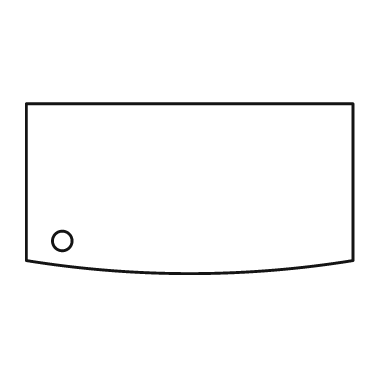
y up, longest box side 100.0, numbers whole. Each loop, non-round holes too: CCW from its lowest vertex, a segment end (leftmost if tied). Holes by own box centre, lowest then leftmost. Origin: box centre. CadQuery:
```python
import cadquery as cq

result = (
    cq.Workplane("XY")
    .moveTo(-50.0, -22.0)
    .threePointArc((0.0, -26.0), (50.0, -22.0))
    .lineTo(50.0, 26.0)
    .lineTo(-50.0, 26.0)
    .close()
    .moveTo(-39.0, -16.0)
    .circle(3.0)
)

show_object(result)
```